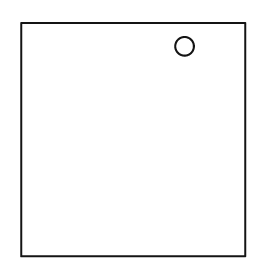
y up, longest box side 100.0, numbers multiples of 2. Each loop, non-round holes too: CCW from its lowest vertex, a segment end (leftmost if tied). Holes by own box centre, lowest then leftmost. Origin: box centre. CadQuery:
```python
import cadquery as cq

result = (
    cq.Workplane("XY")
    .moveTo(-48.0, -50.0)
    .lineTo(48.0, -50.0)
    .lineTo(48.0, 50.0)
    .lineTo(-48.0, 50.0)
    .close()
    .moveTo(22.0, 40.0)
    .circle(4.0)
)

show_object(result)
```